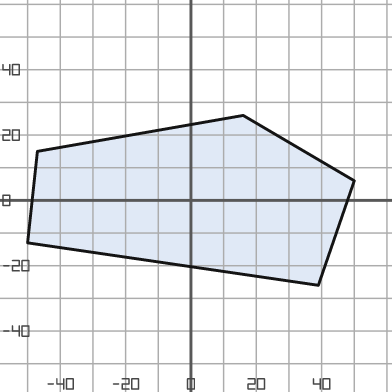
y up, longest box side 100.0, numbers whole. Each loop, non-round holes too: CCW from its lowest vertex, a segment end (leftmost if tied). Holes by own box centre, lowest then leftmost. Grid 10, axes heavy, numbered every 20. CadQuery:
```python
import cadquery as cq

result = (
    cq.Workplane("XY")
    .moveTo(39.0, -26.0)
    .lineTo(50.0, 6.0)
    .lineTo(16.0, 26.0)
    .lineTo(-47.0, 15.0)
    .lineTo(-50.0, -13.0)
    .close()
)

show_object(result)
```